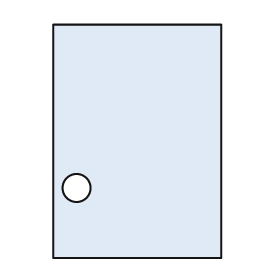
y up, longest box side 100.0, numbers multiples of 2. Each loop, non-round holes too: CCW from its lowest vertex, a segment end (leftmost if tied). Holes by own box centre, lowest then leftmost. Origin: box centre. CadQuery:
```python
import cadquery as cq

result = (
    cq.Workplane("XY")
    .moveTo(-36.0, -50.0)
    .lineTo(36.0, -50.0)
    .lineTo(36.0, 50.0)
    .lineTo(-36.0, 50.0)
    .close()
    .moveTo(-26.0, -20.0)
    .circle(6.0)
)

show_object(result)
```